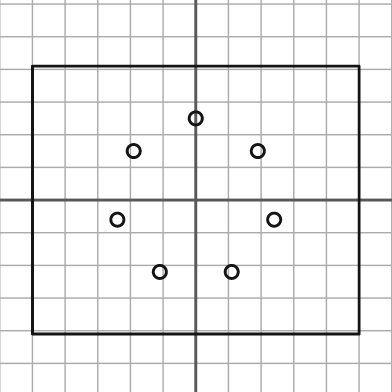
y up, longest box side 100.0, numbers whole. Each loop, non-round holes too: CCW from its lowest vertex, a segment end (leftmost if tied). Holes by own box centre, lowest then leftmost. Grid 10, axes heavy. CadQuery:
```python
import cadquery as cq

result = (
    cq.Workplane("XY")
    .moveTo(-50.0, -41.0)
    .lineTo(50.0, -41.0)
    .lineTo(50.0, 41.0)
    .lineTo(-50.0, 41.0)
    .close()
    .moveTo(-11.0, -22.0)
    .circle(2.0)
    .moveTo(11.0, -22.0)
    .circle(2.0)
    .moveTo(-24.0, -6.0)
    .circle(2.0)
    .moveTo(24.0, -6.0)
    .circle(2.0)
    .moveTo(-19.0, 15.0)
    .circle(2.0)
    .moveTo(19.0, 15.0)
    .circle(2.0)
    .moveTo(0.0, 25.0)
    .circle(2.0)
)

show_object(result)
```